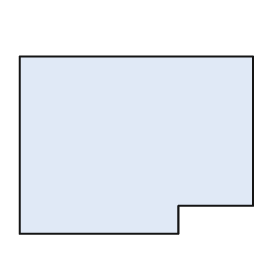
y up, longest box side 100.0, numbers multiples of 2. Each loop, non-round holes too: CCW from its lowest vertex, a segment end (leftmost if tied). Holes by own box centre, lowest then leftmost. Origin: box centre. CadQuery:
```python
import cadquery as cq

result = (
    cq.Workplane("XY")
    .moveTo(-50.0, -38.0)
    .lineTo(18.0, -38.0)
    .lineTo(18.0, -26.0)
    .lineTo(50.0, -26.0)
    .lineTo(50.0, 38.0)
    .lineTo(-50.0, 38.0)
    .close()
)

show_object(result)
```